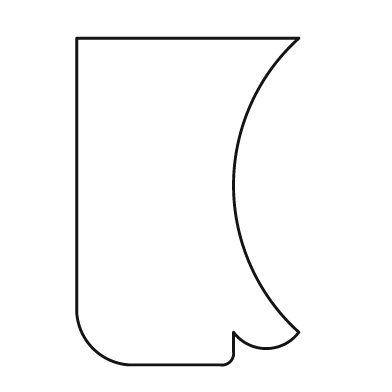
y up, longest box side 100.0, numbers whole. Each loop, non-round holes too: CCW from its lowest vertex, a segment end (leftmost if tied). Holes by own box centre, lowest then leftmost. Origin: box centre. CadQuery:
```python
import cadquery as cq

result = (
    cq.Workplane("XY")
    .moveTo(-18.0, -50.0)
    .lineTo(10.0, -50.0)
    .threePointArc((13.0, -49.0), (14.0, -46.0))
    .lineTo(14.0, -40.0)
    .threePointArc((24.0, -45.0), (34.0, -40.0))
    .threePointArc((14.0, 5.0), (34.0, 50.0))
    .lineTo(-34.0, 50.0)
    .lineTo(-34.0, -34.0)
    .threePointArc((-29.0, -45.0), (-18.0, -50.0))
    .close()
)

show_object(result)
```